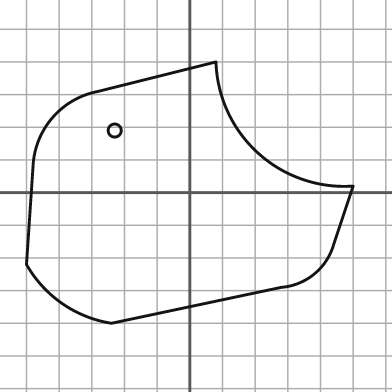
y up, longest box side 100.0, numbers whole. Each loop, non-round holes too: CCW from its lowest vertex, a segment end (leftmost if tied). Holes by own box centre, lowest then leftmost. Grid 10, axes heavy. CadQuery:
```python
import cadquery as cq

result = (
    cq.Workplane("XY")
    .moveTo(-24.0, -40.0)
    .lineTo(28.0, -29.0)
    .threePointArc((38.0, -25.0), (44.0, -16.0))
    .lineTo(50.0, 2.0)
    .threePointArc((21.0, 12.0), (8.0, 40.0))
    .lineTo(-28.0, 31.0)
    .threePointArc((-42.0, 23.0), (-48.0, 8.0))
    .lineTo(-50.0, -22.0)
    .threePointArc((-39.0, -34.0), (-24.0, -40.0))
    .close()
    .moveTo(-23.0, 19.0)
    .circle(2.0)
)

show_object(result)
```